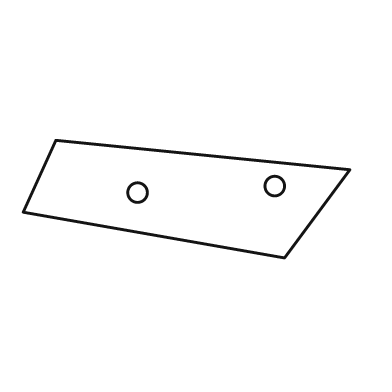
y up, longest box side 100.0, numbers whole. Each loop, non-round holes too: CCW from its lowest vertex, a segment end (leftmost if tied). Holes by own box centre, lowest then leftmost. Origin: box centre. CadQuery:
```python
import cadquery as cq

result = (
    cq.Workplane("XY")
    .moveTo(30.0, -18.0)
    .lineTo(50.0, 9.0)
    .lineTo(-40.0, 18.0)
    .lineTo(-50.0, -4.0)
    .close()
    .moveTo(-15.0, 2.0)
    .circle(3.0)
    .moveTo(27.0, 4.0)
    .circle(3.0)
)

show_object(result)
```